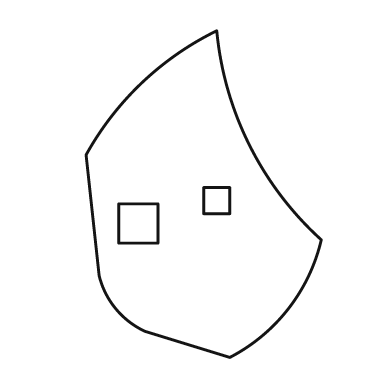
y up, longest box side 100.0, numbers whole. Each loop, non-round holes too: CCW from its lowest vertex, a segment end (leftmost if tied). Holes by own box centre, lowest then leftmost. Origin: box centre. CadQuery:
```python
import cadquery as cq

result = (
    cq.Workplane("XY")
    .moveTo(8.0, -50.0)
    .threePointArc((26.0, -35.0), (36.0, -14.0))
    .threePointArc((14.0, 15.0), (4.0, 50.0))
    .threePointArc((-19.0, 34.0), (-36.0, 12.0))
    .lineTo(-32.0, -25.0)
    .threePointArc((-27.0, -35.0), (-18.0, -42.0))
    .close()
    .moveTo(-26.0, -15.0)
    .lineTo(-14.0, -15.0)
    .lineTo(-14.0, -3.0)
    .lineTo(-26.0, -3.0)
    .close()
    .moveTo(0.0, -6.0)
    .lineTo(8.0, -6.0)
    .lineTo(8.0, 2.0)
    .lineTo(0.0, 2.0)
    .close()
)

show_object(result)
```